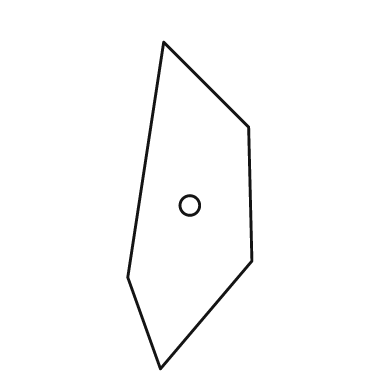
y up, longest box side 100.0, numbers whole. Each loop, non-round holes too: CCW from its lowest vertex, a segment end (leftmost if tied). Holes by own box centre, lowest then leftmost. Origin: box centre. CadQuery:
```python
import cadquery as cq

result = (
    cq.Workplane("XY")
    .moveTo(-9.0, -50.0)
    .lineTo(19.0, -17.0)
    .lineTo(18.0, 24.0)
    .lineTo(-8.0, 50.0)
    .lineTo(-19.0, -22.0)
    .close()
    .moveTo(0.0, 0.0)
    .circle(3.0)
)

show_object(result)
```